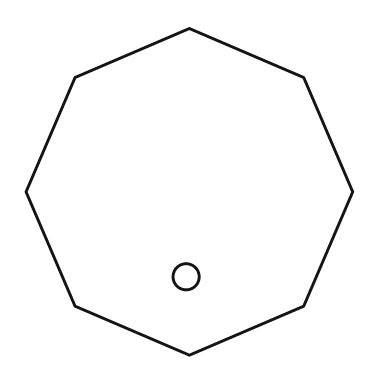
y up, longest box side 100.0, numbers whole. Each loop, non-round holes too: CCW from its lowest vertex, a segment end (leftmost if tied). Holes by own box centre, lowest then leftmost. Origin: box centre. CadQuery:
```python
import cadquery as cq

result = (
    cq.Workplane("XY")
    .moveTo(0.0, -50.0)
    .lineTo(35.0, -35.0)
    .lineTo(50.0, 0.0)
    .lineTo(35.0, 35.0)
    .lineTo(0.0, 50.0)
    .lineTo(-35.0, 35.0)
    .lineTo(-50.0, 0.0)
    .lineTo(-35.0, -35.0)
    .close()
    .moveTo(-1.0, -26.0)
    .circle(4.0)
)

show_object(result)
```